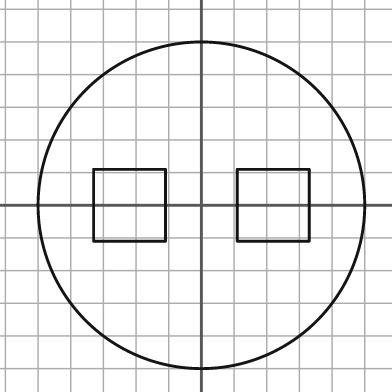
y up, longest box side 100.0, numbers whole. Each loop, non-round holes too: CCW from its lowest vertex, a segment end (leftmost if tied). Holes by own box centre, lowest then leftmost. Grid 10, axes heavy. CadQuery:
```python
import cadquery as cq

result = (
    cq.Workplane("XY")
    .moveTo(0.0, 0.0)
    .circle(50.0)
    .moveTo(-33.0, -11.0)
    .lineTo(-11.0, -11.0)
    .lineTo(-11.0, 11.0)
    .lineTo(-33.0, 11.0)
    .close()
    .moveTo(11.0, -11.0)
    .lineTo(33.0, -11.0)
    .lineTo(33.0, 11.0)
    .lineTo(11.0, 11.0)
    .close()
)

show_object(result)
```